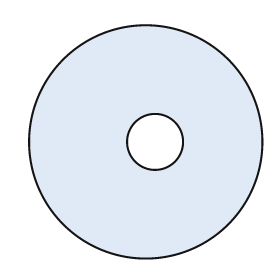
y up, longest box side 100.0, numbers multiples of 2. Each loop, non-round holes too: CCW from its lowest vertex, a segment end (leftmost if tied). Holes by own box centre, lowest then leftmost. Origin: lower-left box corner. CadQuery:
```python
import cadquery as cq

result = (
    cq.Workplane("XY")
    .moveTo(50.0, 50.0)
    .circle(50.0)
    .moveTo(54.0, 50.0)
    .circle(12.0)
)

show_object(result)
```